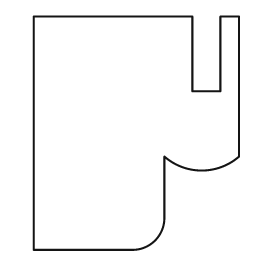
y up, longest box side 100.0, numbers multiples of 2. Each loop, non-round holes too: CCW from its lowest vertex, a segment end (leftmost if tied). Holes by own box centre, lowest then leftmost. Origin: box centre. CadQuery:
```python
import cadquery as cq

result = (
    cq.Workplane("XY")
    .moveTo(-44.0, -50.0)
    .lineTo(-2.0, -50.0)
    .threePointArc((8.0, -46.0), (12.0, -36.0))
    .lineTo(12.0, -10.0)
    .threePointArc((28.0, -16.0), (44.0, -10.0))
    .lineTo(44.0, 50.0)
    .lineTo(36.0, 50.0)
    .lineTo(36.0, 18.0)
    .lineTo(24.0, 18.0)
    .lineTo(24.0, 50.0)
    .lineTo(-44.0, 50.0)
    .close()
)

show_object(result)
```